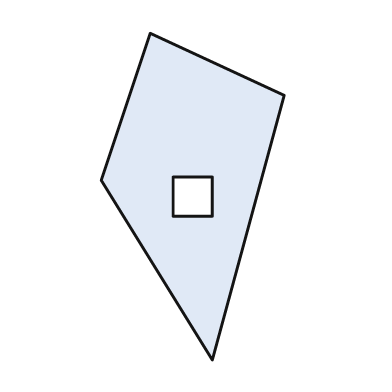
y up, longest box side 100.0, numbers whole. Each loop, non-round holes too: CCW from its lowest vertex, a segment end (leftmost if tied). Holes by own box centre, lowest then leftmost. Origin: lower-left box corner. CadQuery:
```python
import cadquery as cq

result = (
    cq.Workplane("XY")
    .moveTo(34.0, 0.0)
    .lineTo(56.0, 81.0)
    .lineTo(15.0, 100.0)
    .lineTo(0.0, 55.0)
    .close()
    .moveTo(22.0, 44.0)
    .lineTo(34.0, 44.0)
    .lineTo(34.0, 56.0)
    .lineTo(22.0, 56.0)
    .close()
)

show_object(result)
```